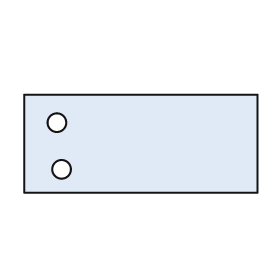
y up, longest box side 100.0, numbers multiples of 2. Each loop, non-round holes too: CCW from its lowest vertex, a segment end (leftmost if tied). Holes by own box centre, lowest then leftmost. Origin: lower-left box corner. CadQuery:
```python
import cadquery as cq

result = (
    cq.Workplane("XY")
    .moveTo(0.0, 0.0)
    .lineTo(100.0, 0.0)
    .lineTo(100.0, 42.0)
    .lineTo(0.0, 42.0)
    .close()
    .moveTo(16.0, 10.0)
    .circle(4.0)
    .moveTo(14.0, 30.0)
    .circle(4.0)
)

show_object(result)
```